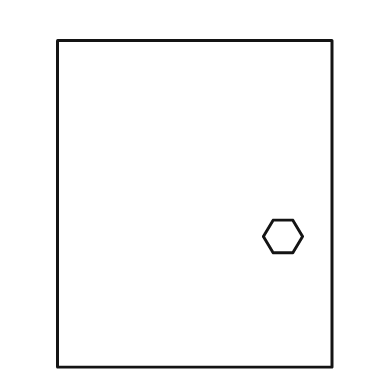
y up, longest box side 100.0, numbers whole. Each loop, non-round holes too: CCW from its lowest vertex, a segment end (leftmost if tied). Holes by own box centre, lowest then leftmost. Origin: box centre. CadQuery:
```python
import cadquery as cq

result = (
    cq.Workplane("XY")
    .moveTo(-42.0, -50.0)
    .lineTo(42.0, -50.0)
    .lineTo(42.0, 50.0)
    .lineTo(-42.0, 50.0)
    .close()
    .moveTo(24.0, -15.0)
    .lineTo(30.0, -15.0)
    .lineTo(33.0, -10.0)
    .lineTo(30.0, -5.0)
    .lineTo(24.0, -5.0)
    .lineTo(21.0, -10.0)
    .close()
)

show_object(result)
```